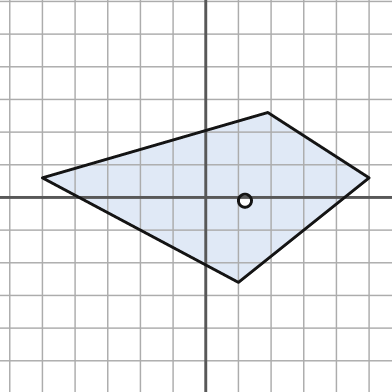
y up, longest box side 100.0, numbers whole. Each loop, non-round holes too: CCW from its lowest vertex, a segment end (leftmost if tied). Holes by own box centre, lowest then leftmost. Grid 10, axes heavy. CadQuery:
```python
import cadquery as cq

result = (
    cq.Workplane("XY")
    .moveTo(10.0, -26.0)
    .lineTo(50.0, 6.0)
    .lineTo(19.0, 26.0)
    .lineTo(-50.0, 6.0)
    .close()
    .moveTo(12.0, -1.0)
    .circle(2.0)
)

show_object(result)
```